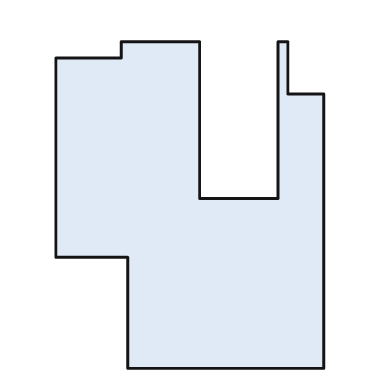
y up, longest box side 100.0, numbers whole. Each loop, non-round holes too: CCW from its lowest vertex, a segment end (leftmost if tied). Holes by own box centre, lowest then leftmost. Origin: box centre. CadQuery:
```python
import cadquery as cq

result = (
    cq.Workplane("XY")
    .moveTo(-19.0, -50.0)
    .lineTo(41.0, -50.0)
    .lineTo(41.0, 34.0)
    .lineTo(30.0, 34.0)
    .lineTo(30.0, 50.0)
    .lineTo(27.0, 50.0)
    .lineTo(27.0, 2.0)
    .lineTo(3.0, 2.0)
    .lineTo(3.0, 50.0)
    .lineTo(-21.0, 50.0)
    .lineTo(-21.0, 45.0)
    .lineTo(-41.0, 45.0)
    .lineTo(-41.0, -16.0)
    .lineTo(-19.0, -16.0)
    .close()
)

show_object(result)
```